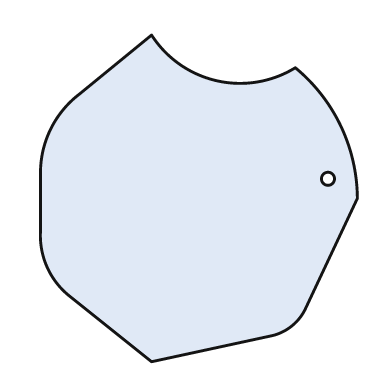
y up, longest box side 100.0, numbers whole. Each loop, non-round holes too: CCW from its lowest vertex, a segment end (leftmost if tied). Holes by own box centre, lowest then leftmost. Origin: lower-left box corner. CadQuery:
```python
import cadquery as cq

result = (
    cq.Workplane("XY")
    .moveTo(34.0, 0.0)
    .lineTo(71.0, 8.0)
    .threePointArc((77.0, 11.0), (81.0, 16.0))
    .lineTo(97.0, 50.0)
    .threePointArc((92.0, 72.0), (78.0, 90.0))
    .threePointArc((54.0, 86.0), (34.0, 100.0))
    .lineTo(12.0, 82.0)
    .threePointArc((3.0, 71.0), (0.0, 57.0))
    .lineTo(0.0, 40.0)
    .threePointArc((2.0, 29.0), (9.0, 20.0))
    .close()
    .moveTo(88.0, 56.0)
    .circle(2.0)
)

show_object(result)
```